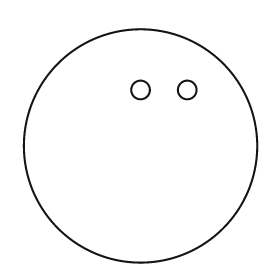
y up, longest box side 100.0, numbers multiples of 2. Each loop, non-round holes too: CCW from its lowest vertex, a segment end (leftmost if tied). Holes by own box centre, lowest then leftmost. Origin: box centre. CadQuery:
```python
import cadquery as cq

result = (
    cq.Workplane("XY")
    .moveTo(0.0, 0.0)
    .circle(50.0)
    .moveTo(0.0, 24.0)
    .circle(4.0)
    .moveTo(20.0, 24.0)
    .circle(4.0)
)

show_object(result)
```